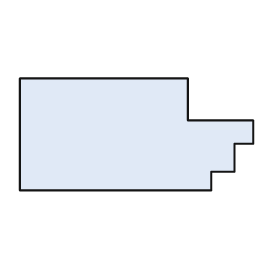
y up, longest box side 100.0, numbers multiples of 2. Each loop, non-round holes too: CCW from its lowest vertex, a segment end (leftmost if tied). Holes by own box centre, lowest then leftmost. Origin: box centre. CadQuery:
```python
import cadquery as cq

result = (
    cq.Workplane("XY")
    .moveTo(-50.0, -24.0)
    .lineTo(32.0, -24.0)
    .lineTo(32.0, -16.0)
    .lineTo(42.0, -16.0)
    .lineTo(42.0, -4.0)
    .lineTo(50.0, -4.0)
    .lineTo(50.0, 6.0)
    .lineTo(22.0, 6.0)
    .lineTo(22.0, 24.0)
    .lineTo(-50.0, 24.0)
    .close()
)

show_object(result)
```